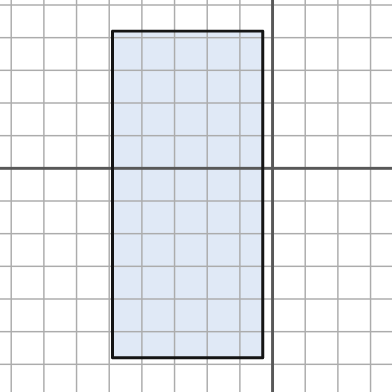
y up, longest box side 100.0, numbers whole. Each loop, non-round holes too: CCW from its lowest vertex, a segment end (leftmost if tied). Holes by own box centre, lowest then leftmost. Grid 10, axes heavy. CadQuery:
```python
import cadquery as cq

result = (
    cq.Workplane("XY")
    .moveTo(-49.0, -58.0)
    .lineTo(-3.0, -58.0)
    .lineTo(-3.0, 42.0)
    .lineTo(-49.0, 42.0)
    .close()
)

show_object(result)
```